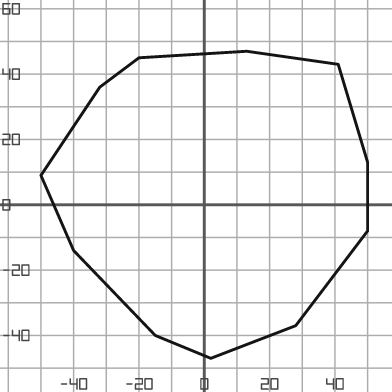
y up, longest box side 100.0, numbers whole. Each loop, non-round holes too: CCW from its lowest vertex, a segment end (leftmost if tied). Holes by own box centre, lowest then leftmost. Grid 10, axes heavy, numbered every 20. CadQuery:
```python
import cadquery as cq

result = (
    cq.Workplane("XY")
    .moveTo(2.0, -47.0)
    .lineTo(28.0, -37.0)
    .lineTo(50.0, -8.0)
    .lineTo(50.0, 13.0)
    .lineTo(41.0, 43.0)
    .lineTo(13.0, 47.0)
    .lineTo(-20.0, 45.0)
    .lineTo(-32.0, 36.0)
    .lineTo(-50.0, 9.0)
    .lineTo(-40.0, -14.0)
    .lineTo(-15.0, -40.0)
    .close()
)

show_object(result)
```